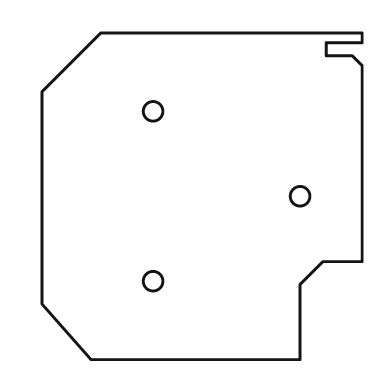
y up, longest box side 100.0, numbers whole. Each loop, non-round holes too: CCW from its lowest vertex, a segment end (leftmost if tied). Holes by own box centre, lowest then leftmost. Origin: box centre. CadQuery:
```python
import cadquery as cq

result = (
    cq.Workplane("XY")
    .moveTo(-34.0, -50.0)
    .lineTo(30.0, -50.0)
    .lineTo(30.0, -27.0)
    .lineTo(37.0, -20.0)
    .lineTo(49.0, -20.0)
    .lineTo(49.0, 40.0)
    .lineTo(46.0, 43.0)
    .lineTo(38.0, 43.0)
    .lineTo(38.0, 47.0)
    .lineTo(49.0, 47.0)
    .lineTo(49.0, 50.0)
    .lineTo(-31.0, 50.0)
    .lineTo(-49.0, 32.0)
    .lineTo(-49.0, -33.0)
    .close()
    .moveTo(-15.0, -26.0)
    .circle(3.0)
    .moveTo(30.0, 0.0)
    .circle(3.0)
    .moveTo(-15.0, 26.0)
    .circle(3.0)
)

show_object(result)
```